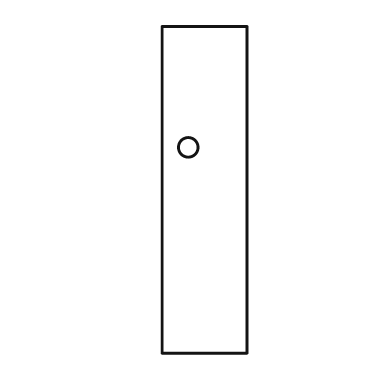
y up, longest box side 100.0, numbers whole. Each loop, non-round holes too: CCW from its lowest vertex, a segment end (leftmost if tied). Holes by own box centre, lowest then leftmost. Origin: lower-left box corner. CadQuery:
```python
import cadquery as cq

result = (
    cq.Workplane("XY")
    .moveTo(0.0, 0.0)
    .lineTo(26.0, 0.0)
    .lineTo(26.0, 100.0)
    .lineTo(0.0, 100.0)
    .close()
    .moveTo(8.0, 63.0)
    .circle(3.0)
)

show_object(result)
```